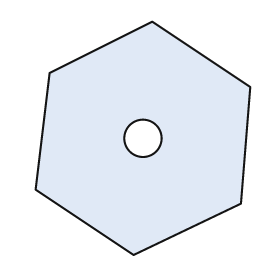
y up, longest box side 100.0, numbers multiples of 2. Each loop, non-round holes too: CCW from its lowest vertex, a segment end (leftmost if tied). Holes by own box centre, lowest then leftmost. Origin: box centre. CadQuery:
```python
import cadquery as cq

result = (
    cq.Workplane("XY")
    .moveTo(-4.0, -50.0)
    .lineTo(42.0, -28.0)
    .lineTo(46.0, 22.0)
    .lineTo(4.0, 50.0)
    .lineTo(-40.0, 28.0)
    .lineTo(-46.0, -22.0)
    .close()
    .moveTo(0.0, 0.0)
    .circle(8.0)
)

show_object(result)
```